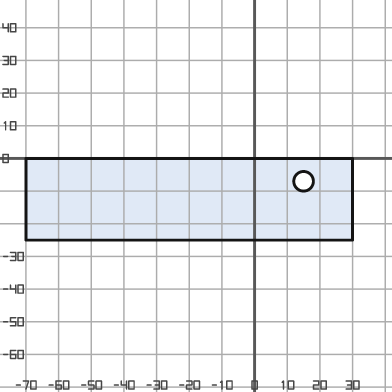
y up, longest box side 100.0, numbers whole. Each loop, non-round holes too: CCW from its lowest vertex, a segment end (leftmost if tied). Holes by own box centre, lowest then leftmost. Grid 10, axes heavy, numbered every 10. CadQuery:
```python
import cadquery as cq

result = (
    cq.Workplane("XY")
    .moveTo(-70.0, -25.0)
    .lineTo(30.0, -25.0)
    .lineTo(30.0, 0.0)
    .lineTo(-70.0, 0.0)
    .close()
    .moveTo(15.0, -7.0)
    .circle(3.0)
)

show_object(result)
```